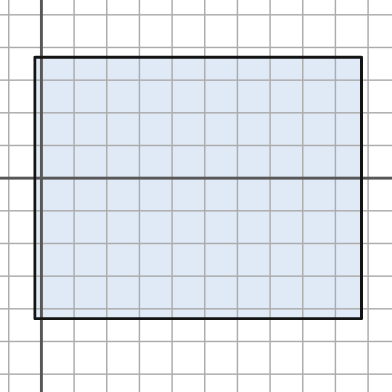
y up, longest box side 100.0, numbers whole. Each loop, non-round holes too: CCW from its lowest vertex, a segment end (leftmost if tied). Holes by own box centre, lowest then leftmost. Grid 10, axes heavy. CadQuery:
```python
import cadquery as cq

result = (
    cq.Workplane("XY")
    .moveTo(-2.0, -43.0)
    .lineTo(98.0, -43.0)
    .lineTo(98.0, 37.0)
    .lineTo(-2.0, 37.0)
    .close()
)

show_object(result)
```